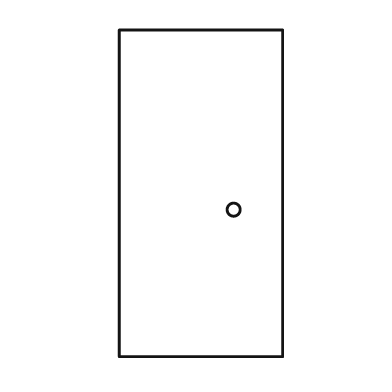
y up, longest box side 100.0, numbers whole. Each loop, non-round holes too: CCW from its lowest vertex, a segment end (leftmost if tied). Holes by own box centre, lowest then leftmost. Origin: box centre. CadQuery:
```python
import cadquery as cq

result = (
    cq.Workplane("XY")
    .moveTo(-25.0, -50.0)
    .lineTo(25.0, -50.0)
    .lineTo(25.0, 50.0)
    .lineTo(-25.0, 50.0)
    .close()
    .moveTo(10.0, -5.0)
    .circle(2.0)
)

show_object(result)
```